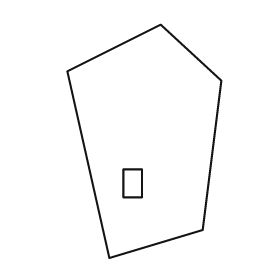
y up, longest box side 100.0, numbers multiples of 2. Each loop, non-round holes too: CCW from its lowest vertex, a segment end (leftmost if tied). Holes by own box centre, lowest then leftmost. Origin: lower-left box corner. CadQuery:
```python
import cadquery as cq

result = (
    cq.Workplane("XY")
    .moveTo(18.0, 0.0)
    .lineTo(58.0, 12.0)
    .lineTo(66.0, 76.0)
    .lineTo(40.0, 100.0)
    .lineTo(0.0, 80.0)
    .close()
    .moveTo(24.0, 26.0)
    .lineTo(32.0, 26.0)
    .lineTo(32.0, 38.0)
    .lineTo(24.0, 38.0)
    .close()
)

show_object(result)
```